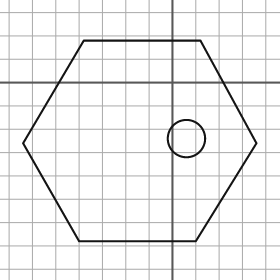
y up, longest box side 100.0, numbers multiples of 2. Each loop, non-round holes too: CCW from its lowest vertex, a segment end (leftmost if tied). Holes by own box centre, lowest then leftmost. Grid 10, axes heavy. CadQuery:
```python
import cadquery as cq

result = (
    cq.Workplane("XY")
    .moveTo(-40.0, -68.0)
    .lineTo(10.0, -68.0)
    .lineTo(36.0, -26.0)
    .lineTo(12.0, 18.0)
    .lineTo(-38.0, 18.0)
    .lineTo(-64.0, -26.0)
    .close()
    .moveTo(6.0, -24.0)
    .circle(8.0)
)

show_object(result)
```